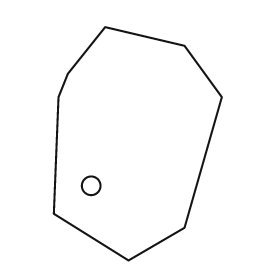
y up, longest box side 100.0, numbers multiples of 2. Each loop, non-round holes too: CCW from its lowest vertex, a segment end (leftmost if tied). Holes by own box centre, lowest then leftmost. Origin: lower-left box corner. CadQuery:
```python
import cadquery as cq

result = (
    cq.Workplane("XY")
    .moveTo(32.0, 0.0)
    .lineTo(56.0, 14.0)
    .lineTo(72.0, 70.0)
    .lineTo(56.0, 92.0)
    .lineTo(22.0, 100.0)
    .lineTo(6.0, 80.0)
    .lineTo(2.0, 70.0)
    .lineTo(0.0, 20.0)
    .close()
    .moveTo(16.0, 32.0)
    .circle(4.0)
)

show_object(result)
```